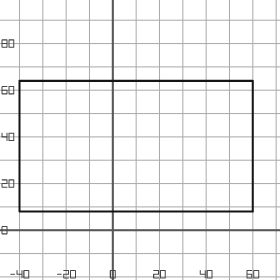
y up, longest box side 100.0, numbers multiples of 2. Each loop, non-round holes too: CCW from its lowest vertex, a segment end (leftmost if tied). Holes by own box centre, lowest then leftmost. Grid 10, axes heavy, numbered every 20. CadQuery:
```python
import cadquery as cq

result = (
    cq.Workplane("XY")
    .moveTo(-40.0, 8.0)
    .lineTo(60.0, 8.0)
    .lineTo(60.0, 64.0)
    .lineTo(-40.0, 64.0)
    .close()
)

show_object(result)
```